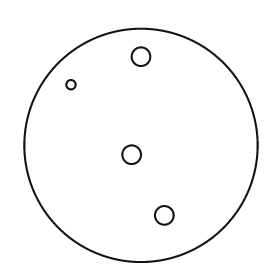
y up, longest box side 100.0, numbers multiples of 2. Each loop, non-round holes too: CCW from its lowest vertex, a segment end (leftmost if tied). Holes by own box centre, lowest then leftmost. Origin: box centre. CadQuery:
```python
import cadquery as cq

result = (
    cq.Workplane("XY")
    .moveTo(0.0, 0.0)
    .circle(50.0)
    .moveTo(10.0, -30.0)
    .circle(4.0)
    .moveTo(-4.0, -4.0)
    .circle(4.0)
    .moveTo(-30.0, 26.0)
    .circle(2.0)
    .moveTo(0.0, 38.0)
    .circle(4.0)
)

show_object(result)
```